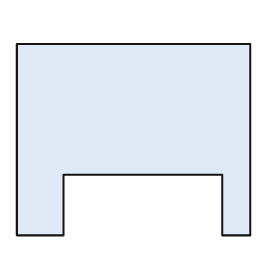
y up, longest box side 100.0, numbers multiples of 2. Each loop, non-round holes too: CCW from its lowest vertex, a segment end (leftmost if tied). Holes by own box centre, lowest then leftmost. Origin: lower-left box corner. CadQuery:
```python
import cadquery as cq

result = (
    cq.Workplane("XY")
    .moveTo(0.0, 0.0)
    .lineTo(20.0, 0.0)
    .lineTo(20.0, 26.0)
    .lineTo(88.0, 26.0)
    .lineTo(88.0, 0.0)
    .lineTo(100.0, 0.0)
    .lineTo(100.0, 82.0)
    .lineTo(0.0, 82.0)
    .close()
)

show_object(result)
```